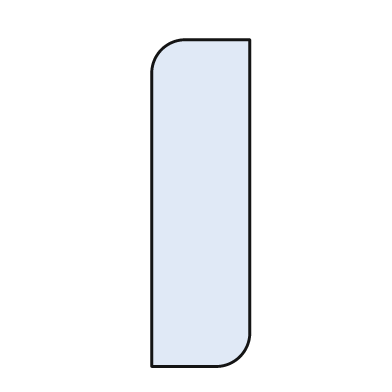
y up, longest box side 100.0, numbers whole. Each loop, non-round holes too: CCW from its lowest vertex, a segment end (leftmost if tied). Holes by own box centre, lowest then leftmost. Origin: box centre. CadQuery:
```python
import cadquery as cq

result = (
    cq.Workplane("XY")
    .moveTo(-15.0, -50.0)
    .lineTo(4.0, -50.0)
    .threePointArc((12.0, -47.0), (15.0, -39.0))
    .lineTo(15.0, 50.0)
    .lineTo(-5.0, 50.0)
    .threePointArc((-12.0, 47.0), (-15.0, 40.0))
    .close()
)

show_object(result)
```